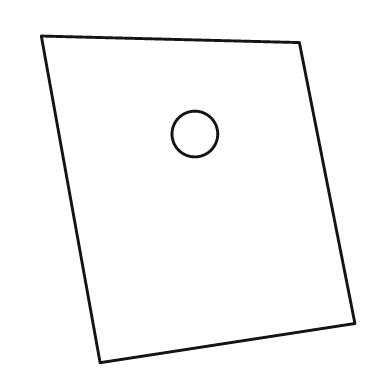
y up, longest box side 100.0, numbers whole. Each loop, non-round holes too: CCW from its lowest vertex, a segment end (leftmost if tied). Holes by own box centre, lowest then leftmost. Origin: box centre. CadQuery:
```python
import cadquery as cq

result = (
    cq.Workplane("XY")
    .moveTo(-30.0, -50.0)
    .lineTo(48.0, -38.0)
    .lineTo(31.0, 48.0)
    .lineTo(-48.0, 50.0)
    .close()
    .moveTo(-1.0, 20.0)
    .circle(7.0)
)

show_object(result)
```